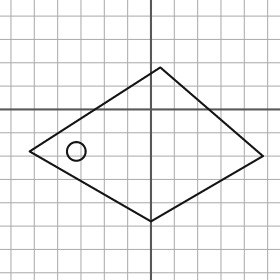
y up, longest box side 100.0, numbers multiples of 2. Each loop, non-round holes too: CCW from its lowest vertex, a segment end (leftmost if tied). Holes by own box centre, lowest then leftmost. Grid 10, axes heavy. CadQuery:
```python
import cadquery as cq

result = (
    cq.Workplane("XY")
    .moveTo(0.0, -48.0)
    .lineTo(48.0, -20.0)
    .lineTo(4.0, 18.0)
    .lineTo(-52.0, -18.0)
    .close()
    .moveTo(-32.0, -18.0)
    .circle(4.0)
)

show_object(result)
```